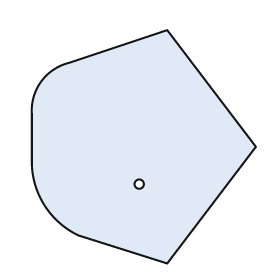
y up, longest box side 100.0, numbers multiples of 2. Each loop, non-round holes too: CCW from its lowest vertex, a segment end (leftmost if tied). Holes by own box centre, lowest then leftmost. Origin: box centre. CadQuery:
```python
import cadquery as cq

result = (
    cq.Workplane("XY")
    .moveTo(10.0, -50.0)
    .lineTo(48.0, 0.0)
    .lineTo(10.0, 50.0)
    .lineTo(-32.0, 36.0)
    .threePointArc((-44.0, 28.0), (-48.0, 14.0))
    .lineTo(-48.0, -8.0)
    .threePointArc((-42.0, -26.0), (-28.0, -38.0))
    .close()
    .moveTo(-2.0, -16.0)
    .circle(2.0)
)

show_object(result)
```